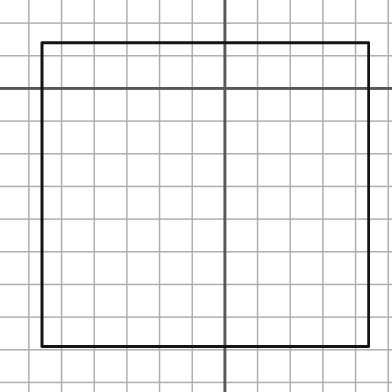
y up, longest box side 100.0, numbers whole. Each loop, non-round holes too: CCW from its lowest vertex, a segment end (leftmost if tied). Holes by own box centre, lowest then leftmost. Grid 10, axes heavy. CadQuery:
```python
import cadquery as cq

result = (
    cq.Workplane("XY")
    .moveTo(-56.0, -79.0)
    .lineTo(44.0, -79.0)
    .lineTo(44.0, 14.0)
    .lineTo(-56.0, 14.0)
    .close()
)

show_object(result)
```